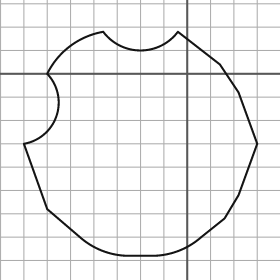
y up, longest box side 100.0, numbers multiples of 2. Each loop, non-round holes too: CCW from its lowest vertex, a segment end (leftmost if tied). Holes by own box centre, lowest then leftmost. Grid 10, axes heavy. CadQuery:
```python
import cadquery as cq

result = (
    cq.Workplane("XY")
    .moveTo(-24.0, -78.0)
    .lineTo(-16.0, -78.0)
    .threePointArc((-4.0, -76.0), (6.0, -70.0))
    .lineTo(16.0, -62.0)
    .lineTo(22.0, -52.0)
    .lineTo(30.0, -30.0)
    .lineTo(22.0, -8.0)
    .lineTo(14.0, 4.0)
    .lineTo(-4.0, 18.0)
    .threePointArc((-20.0, 10.0), (-36.0, 18.0))
    .threePointArc((-50.0, 12.0), (-60.0, 0.0))
    .threePointArc((-56.0, -18.0), (-70.0, -30.0))
    .lineTo(-60.0, -58.0)
    .lineTo(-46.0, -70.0)
    .threePointArc((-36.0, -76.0), (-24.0, -78.0))
    .close()
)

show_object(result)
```